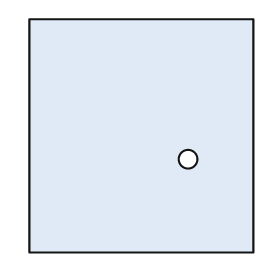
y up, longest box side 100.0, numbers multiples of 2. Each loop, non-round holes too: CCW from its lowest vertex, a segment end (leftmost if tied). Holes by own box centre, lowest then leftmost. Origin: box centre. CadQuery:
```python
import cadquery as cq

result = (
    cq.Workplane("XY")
    .moveTo(-48.0, -50.0)
    .lineTo(48.0, -50.0)
    .lineTo(48.0, 50.0)
    .lineTo(-48.0, 50.0)
    .close()
    .moveTo(20.0, -10.0)
    .circle(4.0)
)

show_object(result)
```